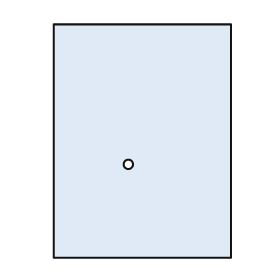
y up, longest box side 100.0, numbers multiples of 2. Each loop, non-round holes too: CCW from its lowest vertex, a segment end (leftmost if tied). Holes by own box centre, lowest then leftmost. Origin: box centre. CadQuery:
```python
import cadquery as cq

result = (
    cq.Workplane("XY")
    .moveTo(-38.0, -50.0)
    .lineTo(38.0, -50.0)
    .lineTo(38.0, 50.0)
    .lineTo(-38.0, 50.0)
    .close()
    .moveTo(-6.0, -10.0)
    .circle(2.0)
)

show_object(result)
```